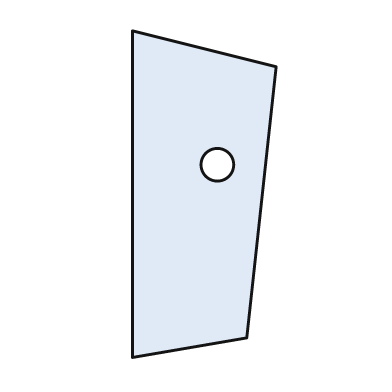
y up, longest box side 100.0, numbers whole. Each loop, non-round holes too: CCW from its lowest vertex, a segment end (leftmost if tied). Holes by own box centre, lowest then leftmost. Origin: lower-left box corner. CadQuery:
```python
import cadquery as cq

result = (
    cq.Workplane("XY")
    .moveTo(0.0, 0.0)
    .lineTo(35.0, 6.0)
    .lineTo(44.0, 89.0)
    .lineTo(0.0, 100.0)
    .close()
    .moveTo(26.0, 59.0)
    .circle(5.0)
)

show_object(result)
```